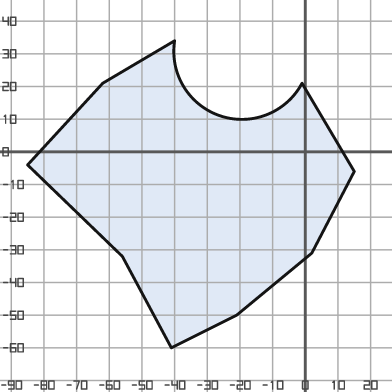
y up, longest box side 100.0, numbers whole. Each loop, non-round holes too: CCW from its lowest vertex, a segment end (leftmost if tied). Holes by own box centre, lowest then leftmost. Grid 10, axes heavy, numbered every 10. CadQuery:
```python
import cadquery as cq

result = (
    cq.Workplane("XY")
    .moveTo(-41.0, -60.0)
    .lineTo(-21.0, -50.0)
    .lineTo(2.0, -31.0)
    .lineTo(15.0, -6.0)
    .lineTo(-1.0, 21.0)
    .threePointArc((-26.0, 11.0), (-40.0, 34.0))
    .lineTo(-62.0, 21.0)
    .lineTo(-85.0, -4.0)
    .lineTo(-56.0, -32.0)
    .close()
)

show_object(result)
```